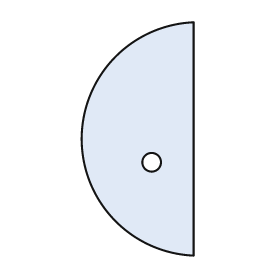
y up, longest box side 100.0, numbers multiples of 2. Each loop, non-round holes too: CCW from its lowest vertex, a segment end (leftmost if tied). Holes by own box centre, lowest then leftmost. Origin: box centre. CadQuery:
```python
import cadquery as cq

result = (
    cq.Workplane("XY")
    .moveTo(24.0, -50.0)
    .lineTo(24.0, 50.0)
    .threePointArc((-24.0, 0.0), (24.0, -50.0))
    .close()
    .moveTo(6.0, -10.0)
    .circle(4.0)
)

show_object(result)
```